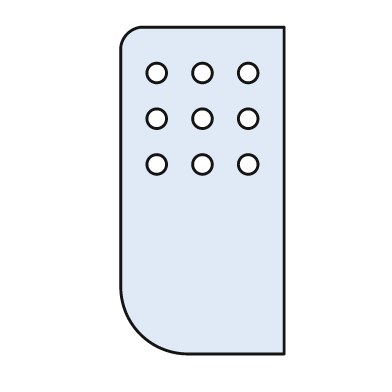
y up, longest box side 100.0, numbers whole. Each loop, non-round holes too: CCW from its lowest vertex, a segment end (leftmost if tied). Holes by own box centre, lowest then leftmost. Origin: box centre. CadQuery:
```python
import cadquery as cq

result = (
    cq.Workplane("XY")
    .moveTo(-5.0, -50.0)
    .lineTo(25.0, -50.0)
    .lineTo(25.0, 50.0)
    .lineTo(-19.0, 50.0)
    .threePointArc((-23.0, 48.0), (-25.0, 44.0))
    .lineTo(-25.0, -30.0)
    .threePointArc((-19.0, -44.0), (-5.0, -50.0))
    .close()
    .moveTo(-14.0, 8.0)
    .circle(3.0)
    .moveTo(0.0, 8.0)
    .circle(3.0)
    .moveTo(14.0, 8.0)
    .circle(3.0)
    .moveTo(-14.0, 22.0)
    .circle(3.0)
    .moveTo(0.0, 22.0)
    .circle(3.0)
    .moveTo(14.0, 22.0)
    .circle(3.0)
    .moveTo(-14.0, 36.0)
    .circle(3.0)
    .moveTo(0.0, 36.0)
    .circle(3.0)
    .moveTo(14.0, 36.0)
    .circle(3.0)
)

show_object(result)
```